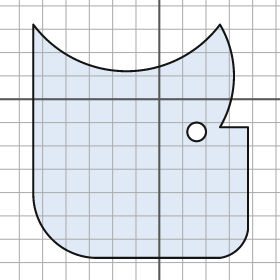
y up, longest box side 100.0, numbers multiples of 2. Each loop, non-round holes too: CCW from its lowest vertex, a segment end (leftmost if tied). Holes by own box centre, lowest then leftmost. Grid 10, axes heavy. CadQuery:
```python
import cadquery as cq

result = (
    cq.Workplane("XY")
    .moveTo(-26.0, -68.0)
    .lineTo(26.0, -68.0)
    .threePointArc((34.0, -64.0), (38.0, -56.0))
    .lineTo(38.0, -12.0)
    .lineTo(26.0, -12.0)
    .threePointArc((32.0, 10.0), (26.0, 32.0))
    .threePointArc((-14.0, 12.0), (-54.0, 32.0))
    .lineTo(-54.0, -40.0)
    .threePointArc((-46.0, -60.0), (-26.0, -68.0))
    .close()
    .moveTo(16.0, -14.0)
    .circle(4.0)
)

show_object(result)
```